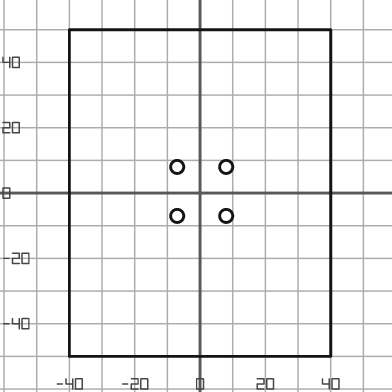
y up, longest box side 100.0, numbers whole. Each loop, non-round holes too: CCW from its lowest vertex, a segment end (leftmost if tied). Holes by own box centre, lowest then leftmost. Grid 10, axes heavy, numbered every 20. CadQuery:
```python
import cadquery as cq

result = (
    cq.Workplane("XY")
    .moveTo(-40.0, -50.0)
    .lineTo(40.0, -50.0)
    .lineTo(40.0, 50.0)
    .lineTo(-40.0, 50.0)
    .close()
    .moveTo(-7.0, -7.0)
    .circle(2.0)
    .moveTo(8.0, -7.0)
    .circle(2.0)
    .moveTo(-7.0, 8.0)
    .circle(2.0)
    .moveTo(8.0, 8.0)
    .circle(2.0)
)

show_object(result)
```